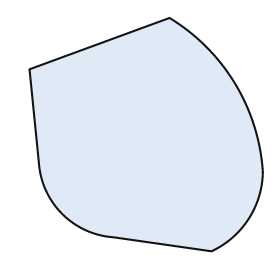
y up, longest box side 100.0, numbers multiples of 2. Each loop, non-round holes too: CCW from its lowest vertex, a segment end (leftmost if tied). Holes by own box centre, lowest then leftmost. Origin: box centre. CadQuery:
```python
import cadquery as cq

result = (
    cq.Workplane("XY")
    .moveTo(28.0, -50.0)
    .threePointArc((44.0, -36.0), (50.0, -16.0))
    .threePointArc((38.0, 22.0), (10.0, 50.0))
    .lineTo(-50.0, 28.0)
    .lineTo(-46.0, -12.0)
    .threePointArc((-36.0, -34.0), (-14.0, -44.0))
    .close()
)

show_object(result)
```